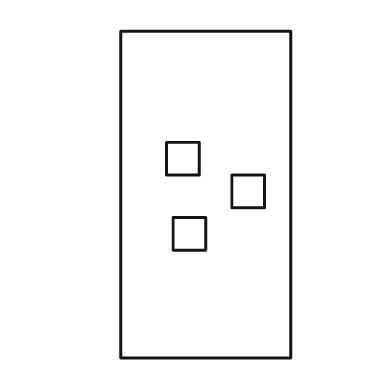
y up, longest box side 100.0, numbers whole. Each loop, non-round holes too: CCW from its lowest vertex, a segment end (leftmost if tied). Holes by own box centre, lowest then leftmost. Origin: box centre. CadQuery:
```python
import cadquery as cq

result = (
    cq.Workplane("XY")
    .moveTo(-26.0, -50.0)
    .lineTo(26.0, -50.0)
    .lineTo(26.0, 50.0)
    .lineTo(-26.0, 50.0)
    .close()
    .moveTo(-10.0, -17.0)
    .lineTo(0.0, -17.0)
    .lineTo(0.0, -7.0)
    .lineTo(-10.0, -7.0)
    .close()
    .moveTo(8.0, -4.0)
    .lineTo(18.0, -4.0)
    .lineTo(18.0, 6.0)
    .lineTo(8.0, 6.0)
    .close()
    .moveTo(-12.0, 6.0)
    .lineTo(-2.0, 6.0)
    .lineTo(-2.0, 16.0)
    .lineTo(-12.0, 16.0)
    .close()
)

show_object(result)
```